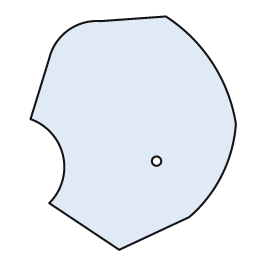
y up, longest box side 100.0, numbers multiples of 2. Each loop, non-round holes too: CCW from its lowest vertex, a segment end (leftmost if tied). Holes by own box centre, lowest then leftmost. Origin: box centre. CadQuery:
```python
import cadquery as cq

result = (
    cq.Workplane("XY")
    .moveTo(-6.0, -50.0)
    .lineTo(24.0, -36.0)
    .threePointArc((38.0, -18.0), (44.0, 4.0))
    .threePointArc((34.0, 30.0), (14.0, 50.0))
    .lineTo(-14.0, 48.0)
    .threePointArc((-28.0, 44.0), (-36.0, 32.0))
    .lineTo(-44.0, 6.0)
    .threePointArc((-30.0, -10.0), (-36.0, -30.0))
    .close()
    .moveTo(10.0, -12.0)
    .circle(2.0)
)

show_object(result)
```